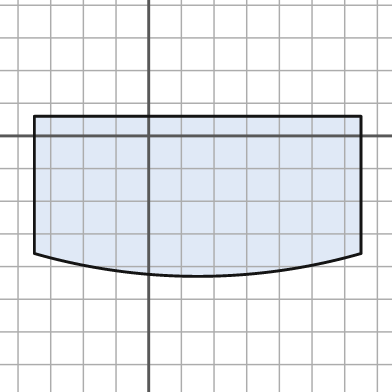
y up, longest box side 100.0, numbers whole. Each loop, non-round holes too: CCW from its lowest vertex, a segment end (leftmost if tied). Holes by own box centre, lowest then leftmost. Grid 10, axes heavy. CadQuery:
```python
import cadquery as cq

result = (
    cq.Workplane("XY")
    .moveTo(-35.0, -36.0)
    .threePointArc((15.0, -43.0), (65.0, -36.0))
    .lineTo(65.0, 6.0)
    .lineTo(-35.0, 6.0)
    .close()
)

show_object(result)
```